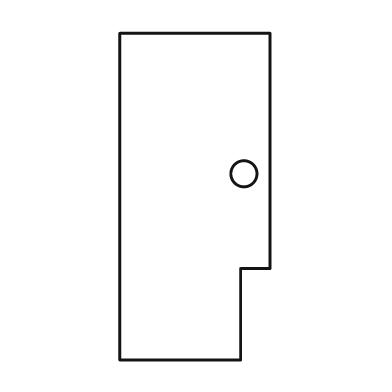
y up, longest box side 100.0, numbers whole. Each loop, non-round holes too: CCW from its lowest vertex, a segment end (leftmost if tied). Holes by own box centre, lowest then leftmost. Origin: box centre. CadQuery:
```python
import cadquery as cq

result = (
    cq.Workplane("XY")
    .moveTo(-23.0, -50.0)
    .lineTo(14.0, -50.0)
    .lineTo(14.0, -22.0)
    .lineTo(23.0, -22.0)
    .lineTo(23.0, 50.0)
    .lineTo(-23.0, 50.0)
    .close()
    .moveTo(15.0, 7.0)
    .circle(4.0)
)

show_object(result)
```